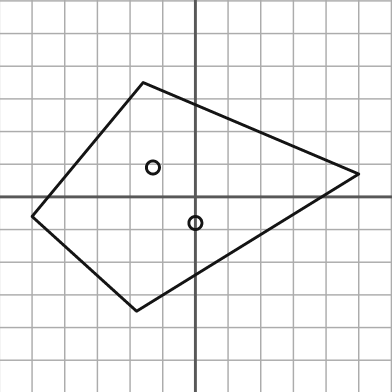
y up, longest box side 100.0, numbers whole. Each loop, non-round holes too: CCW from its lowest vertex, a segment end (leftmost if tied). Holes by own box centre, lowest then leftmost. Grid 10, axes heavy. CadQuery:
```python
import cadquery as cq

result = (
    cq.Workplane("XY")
    .moveTo(-18.0, -35.0)
    .lineTo(50.0, 7.0)
    .lineTo(-16.0, 35.0)
    .lineTo(-50.0, -6.0)
    .close()
    .moveTo(0.0, -8.0)
    .circle(2.0)
    .moveTo(-13.0, 9.0)
    .circle(2.0)
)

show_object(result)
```